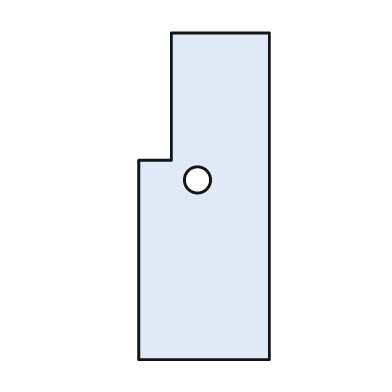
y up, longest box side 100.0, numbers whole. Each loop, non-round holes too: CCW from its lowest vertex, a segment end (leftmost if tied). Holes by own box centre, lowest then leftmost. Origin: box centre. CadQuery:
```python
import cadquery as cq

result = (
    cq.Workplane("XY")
    .moveTo(-20.0, -50.0)
    .lineTo(20.0, -50.0)
    .lineTo(20.0, 50.0)
    .lineTo(-10.0, 50.0)
    .lineTo(-10.0, 11.0)
    .lineTo(-20.0, 11.0)
    .close()
    .moveTo(-2.0, 5.0)
    .circle(4.0)
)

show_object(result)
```